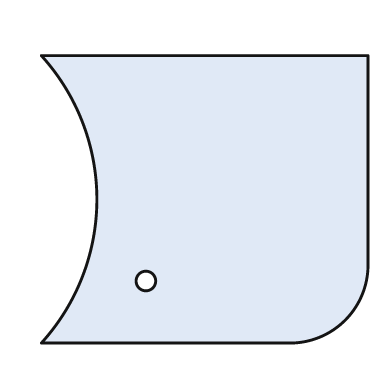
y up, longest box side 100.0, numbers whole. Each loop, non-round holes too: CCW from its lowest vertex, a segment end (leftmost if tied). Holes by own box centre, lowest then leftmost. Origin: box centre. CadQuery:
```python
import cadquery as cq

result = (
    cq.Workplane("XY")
    .moveTo(-50.0, -44.0)
    .lineTo(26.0, -44.0)
    .threePointArc((43.0, -37.0), (50.0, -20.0))
    .lineTo(50.0, 44.0)
    .lineTo(-50.0, 44.0)
    .threePointArc((-33.0, 0.0), (-50.0, -44.0))
    .close()
    .moveTo(-18.0, -25.0)
    .circle(3.0)
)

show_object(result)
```